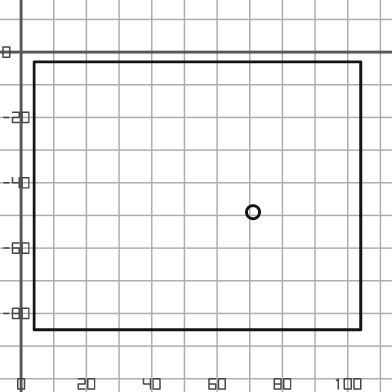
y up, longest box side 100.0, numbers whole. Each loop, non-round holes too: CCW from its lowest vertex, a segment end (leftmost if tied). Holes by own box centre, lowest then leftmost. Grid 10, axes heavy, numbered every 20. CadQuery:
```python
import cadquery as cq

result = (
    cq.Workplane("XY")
    .moveTo(4.0, -85.0)
    .lineTo(104.0, -85.0)
    .lineTo(104.0, -3.0)
    .lineTo(4.0, -3.0)
    .close()
    .moveTo(71.0, -49.0)
    .circle(2.0)
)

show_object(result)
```